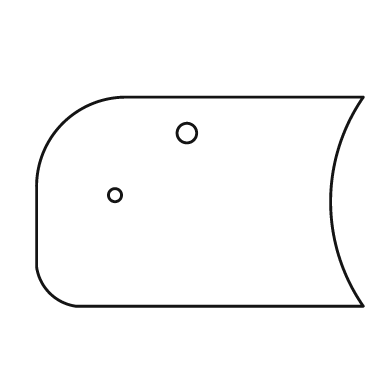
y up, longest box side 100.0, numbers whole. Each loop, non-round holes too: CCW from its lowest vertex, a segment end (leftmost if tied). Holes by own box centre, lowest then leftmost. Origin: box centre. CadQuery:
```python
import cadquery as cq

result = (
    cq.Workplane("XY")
    .moveTo(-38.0, -32.0)
    .lineTo(50.0, -32.0)
    .threePointArc((40.0, 0.0), (50.0, 32.0))
    .lineTo(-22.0, 32.0)
    .threePointArc((-42.0, 24.0), (-50.0, 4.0))
    .lineTo(-50.0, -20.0)
    .threePointArc((-46.0, -28.0), (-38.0, -32.0))
    .close()
    .moveTo(-26.0, 2.0)
    .circle(2.0)
    .moveTo(-4.0, 21.0)
    .circle(3.0)
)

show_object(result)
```